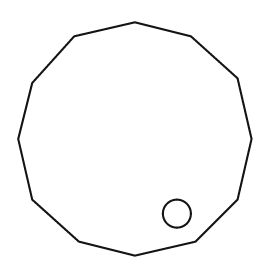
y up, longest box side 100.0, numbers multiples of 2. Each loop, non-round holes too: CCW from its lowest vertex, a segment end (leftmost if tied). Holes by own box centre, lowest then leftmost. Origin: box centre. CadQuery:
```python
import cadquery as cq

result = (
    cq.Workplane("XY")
    .moveTo(0.0, -50.0)
    .lineTo(26.0, -44.0)
    .lineTo(44.0, -26.0)
    .lineTo(50.0, 0.0)
    .lineTo(44.0, 26.0)
    .lineTo(24.0, 44.0)
    .lineTo(0.0, 50.0)
    .lineTo(-26.0, 44.0)
    .lineTo(-44.0, 24.0)
    .lineTo(-50.0, 0.0)
    .lineTo(-44.0, -26.0)
    .lineTo(-24.0, -44.0)
    .close()
    .moveTo(18.0, -32.0)
    .circle(6.0)
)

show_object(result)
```